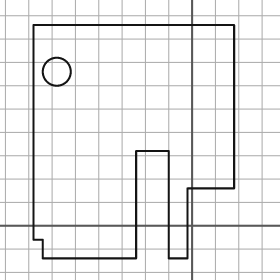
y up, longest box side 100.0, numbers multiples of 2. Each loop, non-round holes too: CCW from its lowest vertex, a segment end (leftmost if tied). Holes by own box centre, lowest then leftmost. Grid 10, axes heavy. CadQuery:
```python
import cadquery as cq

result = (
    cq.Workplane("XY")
    .moveTo(-64.0, -14.0)
    .lineTo(-24.0, -14.0)
    .lineTo(-24.0, 32.0)
    .lineTo(-10.0, 32.0)
    .lineTo(-10.0, -14.0)
    .lineTo(-2.0, -14.0)
    .lineTo(-2.0, 16.0)
    .lineTo(18.0, 16.0)
    .lineTo(18.0, 86.0)
    .lineTo(-68.0, 86.0)
    .lineTo(-68.0, -6.0)
    .lineTo(-64.0, -6.0)
    .close()
    .moveTo(-58.0, 66.0)
    .circle(6.0)
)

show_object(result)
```